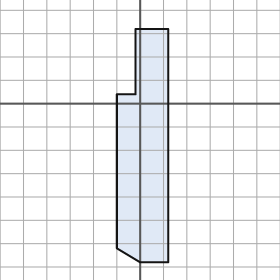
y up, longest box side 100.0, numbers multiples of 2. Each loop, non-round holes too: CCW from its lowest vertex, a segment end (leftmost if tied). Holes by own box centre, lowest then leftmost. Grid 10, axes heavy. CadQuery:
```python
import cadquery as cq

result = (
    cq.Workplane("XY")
    .moveTo(0.0, -68.0)
    .lineTo(12.0, -68.0)
    .lineTo(12.0, 32.0)
    .lineTo(-2.0, 32.0)
    .lineTo(-2.0, 4.0)
    .lineTo(-10.0, 4.0)
    .lineTo(-10.0, -62.0)
    .close()
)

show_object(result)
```